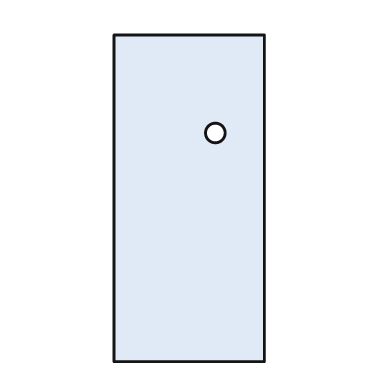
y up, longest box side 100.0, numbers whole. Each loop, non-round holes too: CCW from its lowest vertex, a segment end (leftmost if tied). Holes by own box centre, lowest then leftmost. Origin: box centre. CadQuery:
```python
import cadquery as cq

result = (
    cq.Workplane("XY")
    .moveTo(-23.0, -50.0)
    .lineTo(23.0, -50.0)
    .lineTo(23.0, 50.0)
    .lineTo(-23.0, 50.0)
    .close()
    .moveTo(8.0, 20.0)
    .circle(3.0)
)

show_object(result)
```